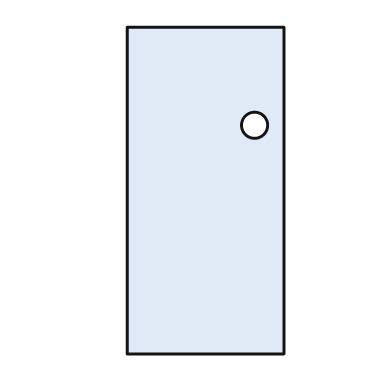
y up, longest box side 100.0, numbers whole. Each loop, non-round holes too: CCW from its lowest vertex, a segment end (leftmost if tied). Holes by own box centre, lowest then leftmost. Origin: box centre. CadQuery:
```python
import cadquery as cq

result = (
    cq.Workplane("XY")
    .moveTo(-24.0, -50.0)
    .lineTo(24.0, -50.0)
    .lineTo(24.0, 50.0)
    .lineTo(-24.0, 50.0)
    .close()
    .moveTo(15.0, 20.0)
    .circle(4.0)
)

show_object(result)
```